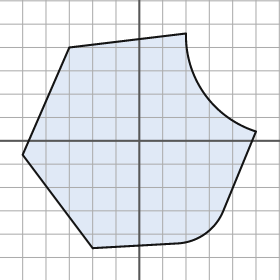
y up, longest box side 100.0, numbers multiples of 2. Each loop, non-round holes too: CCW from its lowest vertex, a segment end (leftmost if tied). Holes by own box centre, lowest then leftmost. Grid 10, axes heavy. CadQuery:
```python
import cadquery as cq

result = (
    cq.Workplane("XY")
    .moveTo(-20.0, -46.0)
    .lineTo(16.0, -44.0)
    .threePointArc((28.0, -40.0), (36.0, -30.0))
    .lineTo(50.0, 4.0)
    .threePointArc((28.0, 20.0), (20.0, 46.0))
    .lineTo(-30.0, 40.0)
    .lineTo(-50.0, -6.0)
    .close()
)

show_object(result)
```